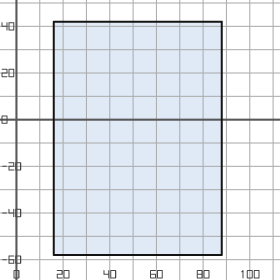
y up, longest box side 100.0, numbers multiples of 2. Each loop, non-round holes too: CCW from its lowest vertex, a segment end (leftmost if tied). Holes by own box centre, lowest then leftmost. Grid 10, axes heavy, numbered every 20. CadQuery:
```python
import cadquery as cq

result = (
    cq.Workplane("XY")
    .moveTo(16.0, -58.0)
    .lineTo(88.0, -58.0)
    .lineTo(88.0, 42.0)
    .lineTo(16.0, 42.0)
    .close()
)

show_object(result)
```